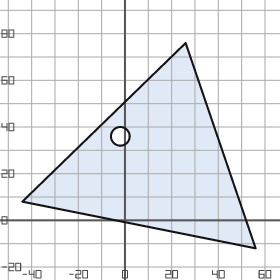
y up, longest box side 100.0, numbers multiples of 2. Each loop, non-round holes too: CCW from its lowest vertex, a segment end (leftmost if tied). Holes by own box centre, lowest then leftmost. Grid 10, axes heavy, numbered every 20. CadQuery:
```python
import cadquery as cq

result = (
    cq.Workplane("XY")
    .moveTo(56.0, -12.0)
    .lineTo(26.0, 76.0)
    .lineTo(-44.0, 8.0)
    .close()
    .moveTo(-2.0, 36.0)
    .circle(4.0)
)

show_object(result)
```